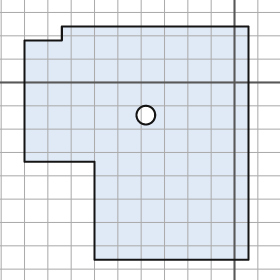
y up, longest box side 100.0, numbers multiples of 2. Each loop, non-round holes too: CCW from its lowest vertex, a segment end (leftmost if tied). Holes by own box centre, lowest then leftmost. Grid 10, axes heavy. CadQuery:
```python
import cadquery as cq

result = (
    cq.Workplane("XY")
    .moveTo(-60.0, -76.0)
    .lineTo(6.0, -76.0)
    .lineTo(6.0, 24.0)
    .lineTo(-74.0, 24.0)
    .lineTo(-74.0, 18.0)
    .lineTo(-90.0, 18.0)
    .lineTo(-90.0, -34.0)
    .lineTo(-60.0, -34.0)
    .close()
    .moveTo(-38.0, -14.0)
    .circle(4.0)
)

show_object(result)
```